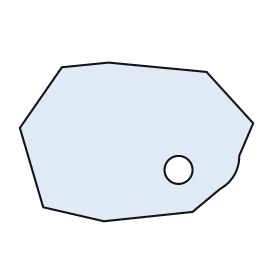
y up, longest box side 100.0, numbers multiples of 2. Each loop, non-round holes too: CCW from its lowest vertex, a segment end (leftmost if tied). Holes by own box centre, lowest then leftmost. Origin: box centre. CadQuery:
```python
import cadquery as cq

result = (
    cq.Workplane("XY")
    .moveTo(-14.0, -34.0)
    .lineTo(24.0, -30.0)
    .lineTo(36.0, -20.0)
    .threePointArc((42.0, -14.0), (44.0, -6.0))
    .lineTo(50.0, 8.0)
    .lineTo(30.0, 30.0)
    .lineTo(-12.0, 34.0)
    .lineTo(-32.0, 32.0)
    .lineTo(-50.0, 6.0)
    .lineTo(-40.0, -28.0)
    .close()
    .moveTo(18.0, -12.0)
    .circle(6.0)
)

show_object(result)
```